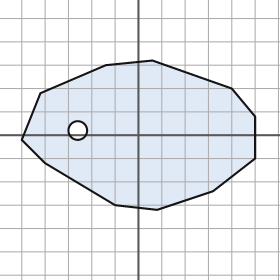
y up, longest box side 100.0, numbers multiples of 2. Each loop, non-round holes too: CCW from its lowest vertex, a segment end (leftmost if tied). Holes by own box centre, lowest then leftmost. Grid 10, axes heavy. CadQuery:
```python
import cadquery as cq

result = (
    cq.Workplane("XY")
    .moveTo(8.0, -32.0)
    .lineTo(32.0, -24.0)
    .lineTo(50.0, -10.0)
    .lineTo(50.0, 8.0)
    .lineTo(40.0, 20.0)
    .lineTo(6.0, 32.0)
    .lineTo(-14.0, 30.0)
    .lineTo(-42.0, 18.0)
    .lineTo(-50.0, -2.0)
    .lineTo(-40.0, -12.0)
    .lineTo(-10.0, -30.0)
    .close()
    .moveTo(-26.0, 2.0)
    .circle(4.0)
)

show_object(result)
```